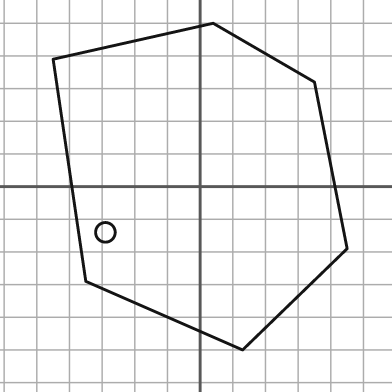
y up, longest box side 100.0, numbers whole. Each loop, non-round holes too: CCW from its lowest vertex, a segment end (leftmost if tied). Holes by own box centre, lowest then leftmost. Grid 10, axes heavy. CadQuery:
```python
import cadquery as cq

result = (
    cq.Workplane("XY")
    .moveTo(13.0, -50.0)
    .lineTo(45.0, -19.0)
    .lineTo(35.0, 32.0)
    .lineTo(4.0, 50.0)
    .lineTo(-45.0, 39.0)
    .lineTo(-35.0, -29.0)
    .close()
    .moveTo(-29.0, -14.0)
    .circle(3.0)
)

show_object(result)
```